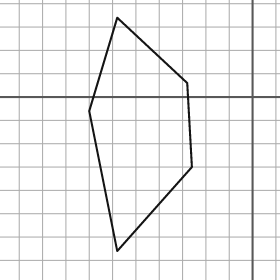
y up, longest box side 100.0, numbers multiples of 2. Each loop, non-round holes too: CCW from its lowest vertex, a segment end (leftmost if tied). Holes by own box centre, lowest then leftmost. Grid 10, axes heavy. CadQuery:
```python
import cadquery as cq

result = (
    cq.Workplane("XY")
    .moveTo(-58.0, -66.0)
    .lineTo(-26.0, -30.0)
    .lineTo(-28.0, 6.0)
    .lineTo(-58.0, 34.0)
    .lineTo(-70.0, -6.0)
    .close()
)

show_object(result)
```